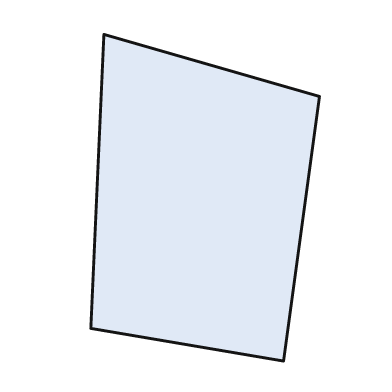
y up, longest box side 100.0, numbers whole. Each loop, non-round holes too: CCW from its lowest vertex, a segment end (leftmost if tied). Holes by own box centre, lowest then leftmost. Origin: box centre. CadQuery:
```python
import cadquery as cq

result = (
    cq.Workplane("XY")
    .moveTo(24.0, -50.0)
    .lineTo(35.0, 31.0)
    .lineTo(-31.0, 50.0)
    .lineTo(-35.0, -40.0)
    .close()
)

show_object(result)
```